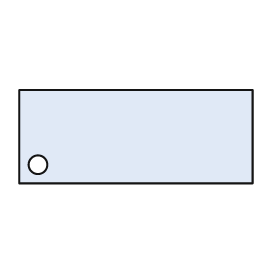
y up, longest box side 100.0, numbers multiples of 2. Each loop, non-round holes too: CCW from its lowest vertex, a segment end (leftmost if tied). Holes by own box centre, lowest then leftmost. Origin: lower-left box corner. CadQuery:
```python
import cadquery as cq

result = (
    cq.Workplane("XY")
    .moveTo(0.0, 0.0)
    .lineTo(100.0, 0.0)
    .lineTo(100.0, 40.0)
    .lineTo(0.0, 40.0)
    .close()
    .moveTo(8.0, 8.0)
    .circle(4.0)
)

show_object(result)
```